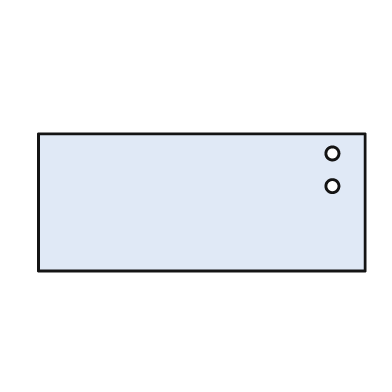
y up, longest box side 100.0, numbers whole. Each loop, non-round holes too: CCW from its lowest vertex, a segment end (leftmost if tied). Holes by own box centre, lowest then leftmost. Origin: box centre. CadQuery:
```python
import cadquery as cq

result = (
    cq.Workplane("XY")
    .moveTo(-50.0, -21.0)
    .lineTo(50.0, -21.0)
    .lineTo(50.0, 21.0)
    .lineTo(-50.0, 21.0)
    .close()
    .moveTo(40.0, 5.0)
    .circle(2.0)
    .moveTo(40.0, 15.0)
    .circle(2.0)
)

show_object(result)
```